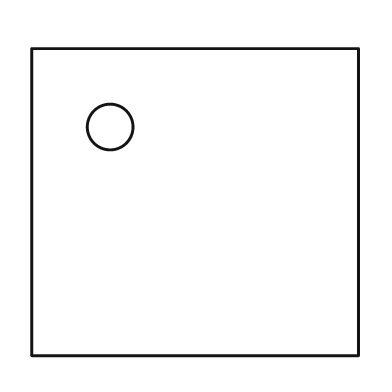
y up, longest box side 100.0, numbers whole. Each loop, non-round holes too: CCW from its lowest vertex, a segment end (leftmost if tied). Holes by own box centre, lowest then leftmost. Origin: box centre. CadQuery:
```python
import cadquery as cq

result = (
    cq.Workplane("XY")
    .moveTo(-50.0, -47.0)
    .lineTo(50.0, -47.0)
    .lineTo(50.0, 47.0)
    .lineTo(-50.0, 47.0)
    .close()
    .moveTo(-26.0, 23.0)
    .circle(7.0)
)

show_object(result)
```